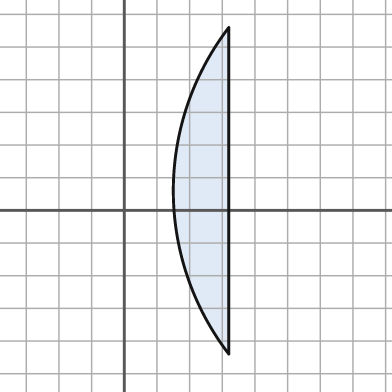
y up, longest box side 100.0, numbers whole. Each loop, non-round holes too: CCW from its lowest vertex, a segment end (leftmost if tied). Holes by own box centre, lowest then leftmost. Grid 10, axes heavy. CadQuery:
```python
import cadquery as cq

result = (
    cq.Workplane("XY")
    .moveTo(32.0, -44.0)
    .lineTo(32.0, 56.0)
    .threePointArc((15.0, 6.0), (32.0, -44.0))
    .close()
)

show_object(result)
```